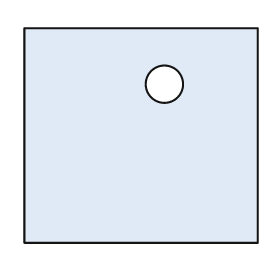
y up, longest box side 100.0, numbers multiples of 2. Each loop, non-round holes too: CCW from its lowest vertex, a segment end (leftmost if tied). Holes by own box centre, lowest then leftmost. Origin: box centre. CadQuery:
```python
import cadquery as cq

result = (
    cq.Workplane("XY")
    .moveTo(-50.0, -46.0)
    .lineTo(50.0, -46.0)
    .lineTo(50.0, 46.0)
    .lineTo(-50.0, 46.0)
    .close()
    .moveTo(10.0, 22.0)
    .circle(8.0)
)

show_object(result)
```